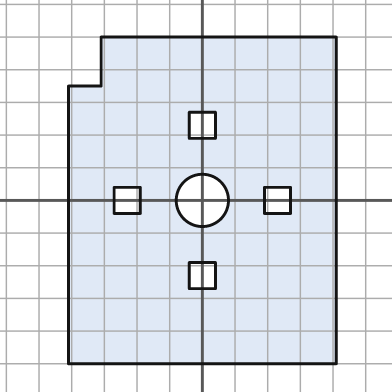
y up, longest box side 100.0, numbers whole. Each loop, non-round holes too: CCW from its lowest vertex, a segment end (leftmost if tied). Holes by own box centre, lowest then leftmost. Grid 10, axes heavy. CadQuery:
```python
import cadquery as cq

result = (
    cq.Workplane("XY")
    .moveTo(-41.0, -50.0)
    .lineTo(41.0, -50.0)
    .lineTo(41.0, 50.0)
    .lineTo(-31.0, 50.0)
    .lineTo(-31.0, 35.0)
    .lineTo(-41.0, 35.0)
    .close()
    .moveTo(-4.0, -27.0)
    .lineTo(4.0, -27.0)
    .lineTo(4.0, -19.0)
    .lineTo(-4.0, -19.0)
    .close()
    .moveTo(-27.0, -4.0)
    .lineTo(-19.0, -4.0)
    .lineTo(-19.0, 4.0)
    .lineTo(-27.0, 4.0)
    .close()
    .moveTo(0.0, 0.0)
    .circle(8.0)
    .moveTo(19.0, -4.0)
    .lineTo(27.0, -4.0)
    .lineTo(27.0, 4.0)
    .lineTo(19.0, 4.0)
    .close()
    .moveTo(-4.0, 19.0)
    .lineTo(4.0, 19.0)
    .lineTo(4.0, 27.0)
    .lineTo(-4.0, 27.0)
    .close()
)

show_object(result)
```